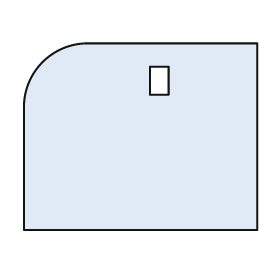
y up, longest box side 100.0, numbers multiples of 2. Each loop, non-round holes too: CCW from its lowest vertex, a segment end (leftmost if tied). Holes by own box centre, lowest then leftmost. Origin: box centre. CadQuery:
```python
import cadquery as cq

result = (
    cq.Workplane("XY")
    .moveTo(-50.0, -40.0)
    .lineTo(50.0, -40.0)
    .lineTo(50.0, 40.0)
    .lineTo(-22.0, 40.0)
    .threePointArc((-42.0, 32.0), (-50.0, 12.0))
    .close()
    .moveTo(4.0, 18.0)
    .lineTo(12.0, 18.0)
    .lineTo(12.0, 30.0)
    .lineTo(4.0, 30.0)
    .close()
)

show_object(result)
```